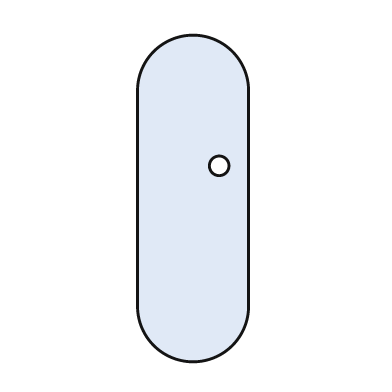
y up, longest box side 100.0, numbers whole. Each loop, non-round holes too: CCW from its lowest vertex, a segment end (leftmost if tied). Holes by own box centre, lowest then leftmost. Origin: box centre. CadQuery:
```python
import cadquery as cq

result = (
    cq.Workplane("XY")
    .moveTo(-17.0, -33.0)
    .threePointArc((0.0, -50.0), (17.0, -33.0))
    .lineTo(17.0, 33.0)
    .threePointArc((0.0, 50.0), (-17.0, 33.0))
    .close()
    .moveTo(8.0, 10.0)
    .circle(3.0)
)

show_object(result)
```